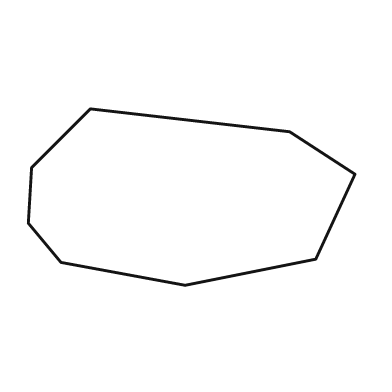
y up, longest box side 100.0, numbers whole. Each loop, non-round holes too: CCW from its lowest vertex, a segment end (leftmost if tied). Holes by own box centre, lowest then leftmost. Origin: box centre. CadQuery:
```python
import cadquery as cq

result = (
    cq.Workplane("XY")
    .moveTo(-2.0, -27.0)
    .lineTo(38.0, -19.0)
    .lineTo(50.0, 7.0)
    .lineTo(30.0, 20.0)
    .lineTo(-31.0, 27.0)
    .lineTo(-49.0, 9.0)
    .lineTo(-50.0, -8.0)
    .lineTo(-40.0, -20.0)
    .close()
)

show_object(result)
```